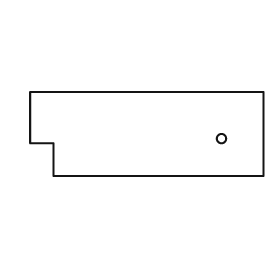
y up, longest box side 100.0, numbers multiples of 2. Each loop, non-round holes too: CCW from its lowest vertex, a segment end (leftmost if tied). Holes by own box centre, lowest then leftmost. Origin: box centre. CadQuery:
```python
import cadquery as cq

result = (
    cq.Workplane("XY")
    .moveTo(-40.0, -18.0)
    .lineTo(50.0, -18.0)
    .lineTo(50.0, 18.0)
    .lineTo(-50.0, 18.0)
    .lineTo(-50.0, -4.0)
    .lineTo(-40.0, -4.0)
    .close()
    .moveTo(32.0, -2.0)
    .circle(2.0)
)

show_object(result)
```